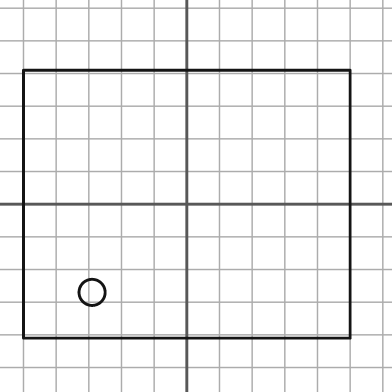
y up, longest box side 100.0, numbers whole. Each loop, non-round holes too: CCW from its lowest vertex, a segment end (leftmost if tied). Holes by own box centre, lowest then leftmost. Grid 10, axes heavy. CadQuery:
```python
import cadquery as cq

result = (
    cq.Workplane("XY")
    .moveTo(-50.0, -41.0)
    .lineTo(50.0, -41.0)
    .lineTo(50.0, 41.0)
    .lineTo(-50.0, 41.0)
    .close()
    .moveTo(-29.0, -27.0)
    .circle(4.0)
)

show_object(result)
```